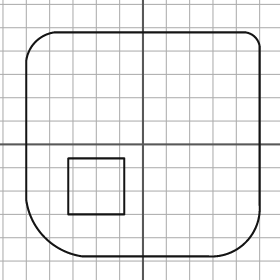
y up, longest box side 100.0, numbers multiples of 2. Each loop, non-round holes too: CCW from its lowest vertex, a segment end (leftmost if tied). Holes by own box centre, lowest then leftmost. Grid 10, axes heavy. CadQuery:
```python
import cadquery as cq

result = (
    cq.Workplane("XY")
    .moveTo(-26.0, -48.0)
    .lineTo(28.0, -48.0)
    .threePointArc((44.0, -42.0), (50.0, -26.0))
    .lineTo(50.0, 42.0)
    .threePointArc((48.0, 46.0), (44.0, 48.0))
    .lineTo(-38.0, 48.0)
    .threePointArc((-46.0, 44.0), (-50.0, 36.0))
    .lineTo(-50.0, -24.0)
    .threePointArc((-42.0, -40.0), (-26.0, -48.0))
    .close()
    .moveTo(-32.0, -30.0)
    .lineTo(-8.0, -30.0)
    .lineTo(-8.0, -6.0)
    .lineTo(-32.0, -6.0)
    .close()
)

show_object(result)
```